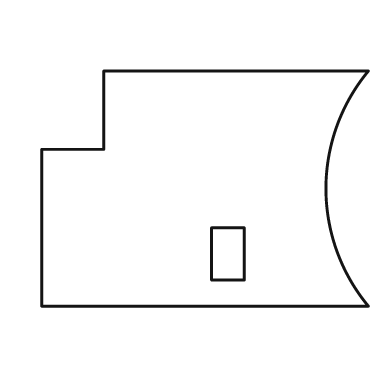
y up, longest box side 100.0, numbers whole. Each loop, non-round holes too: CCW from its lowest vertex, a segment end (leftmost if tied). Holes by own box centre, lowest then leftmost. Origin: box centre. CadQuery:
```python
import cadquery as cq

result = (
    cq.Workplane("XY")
    .moveTo(-50.0, -36.0)
    .lineTo(50.0, -36.0)
    .threePointArc((37.0, 0.0), (50.0, 36.0))
    .lineTo(-31.0, 36.0)
    .lineTo(-31.0, 12.0)
    .lineTo(-50.0, 12.0)
    .close()
    .moveTo(2.0, -28.0)
    .lineTo(12.0, -28.0)
    .lineTo(12.0, -12.0)
    .lineTo(2.0, -12.0)
    .close()
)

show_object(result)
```